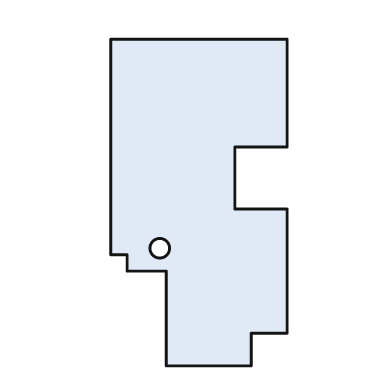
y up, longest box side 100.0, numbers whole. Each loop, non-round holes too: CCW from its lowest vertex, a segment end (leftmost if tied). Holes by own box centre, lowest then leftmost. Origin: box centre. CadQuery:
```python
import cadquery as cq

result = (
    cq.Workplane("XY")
    .moveTo(-10.0, -50.0)
    .lineTo(16.0, -50.0)
    .lineTo(16.0, -40.0)
    .lineTo(27.0, -40.0)
    .lineTo(27.0, -2.0)
    .lineTo(11.0, -2.0)
    .lineTo(11.0, 17.0)
    .lineTo(27.0, 17.0)
    .lineTo(27.0, 50.0)
    .lineTo(-27.0, 50.0)
    .lineTo(-27.0, -16.0)
    .lineTo(-22.0, -16.0)
    .lineTo(-22.0, -21.0)
    .lineTo(-10.0, -21.0)
    .close()
    .moveTo(-12.0, -14.0)
    .circle(3.0)
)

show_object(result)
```